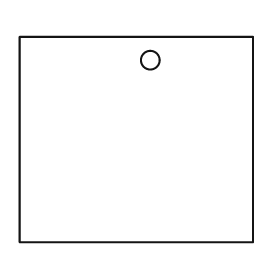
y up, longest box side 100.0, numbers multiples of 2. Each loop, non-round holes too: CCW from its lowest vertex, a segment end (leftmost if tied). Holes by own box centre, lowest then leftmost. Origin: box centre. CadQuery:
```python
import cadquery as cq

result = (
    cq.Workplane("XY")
    .moveTo(-50.0, -44.0)
    .lineTo(50.0, -44.0)
    .lineTo(50.0, 44.0)
    .lineTo(-50.0, 44.0)
    .close()
    .moveTo(6.0, 34.0)
    .circle(4.0)
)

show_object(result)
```